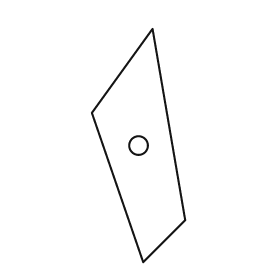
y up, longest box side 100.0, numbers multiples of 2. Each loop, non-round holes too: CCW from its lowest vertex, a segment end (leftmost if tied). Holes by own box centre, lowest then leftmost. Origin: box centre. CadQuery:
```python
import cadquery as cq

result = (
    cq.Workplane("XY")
    .moveTo(2.0, -50.0)
    .lineTo(20.0, -32.0)
    .lineTo(6.0, 50.0)
    .lineTo(-20.0, 14.0)
    .close()
    .moveTo(0.0, 0.0)
    .circle(4.0)
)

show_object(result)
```